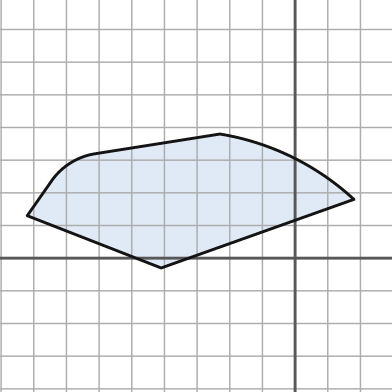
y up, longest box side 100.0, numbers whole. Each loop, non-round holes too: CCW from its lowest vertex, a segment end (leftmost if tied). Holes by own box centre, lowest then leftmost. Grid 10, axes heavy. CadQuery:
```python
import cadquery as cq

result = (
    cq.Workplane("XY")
    .moveTo(-41.0, -3.0)
    .lineTo(18.0, 18.0)
    .threePointArc((-1.0, 31.0), (-23.0, 38.0))
    .lineTo(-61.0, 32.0)
    .threePointArc((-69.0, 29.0), (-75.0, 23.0))
    .lineTo(-82.0, 13.0)
    .close()
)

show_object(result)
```